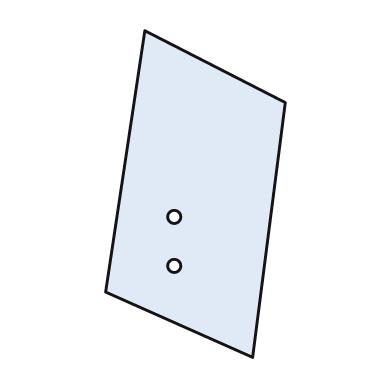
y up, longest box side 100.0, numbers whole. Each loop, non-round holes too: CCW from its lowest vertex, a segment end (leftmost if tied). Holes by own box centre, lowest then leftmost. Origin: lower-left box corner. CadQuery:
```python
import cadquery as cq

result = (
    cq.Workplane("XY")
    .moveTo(45.0, 0.0)
    .lineTo(55.0, 78.0)
    .lineTo(12.0, 100.0)
    .lineTo(0.0, 20.0)
    .close()
    .moveTo(21.0, 28.0)
    .circle(2.0)
    .moveTo(21.0, 43.0)
    .circle(2.0)
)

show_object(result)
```